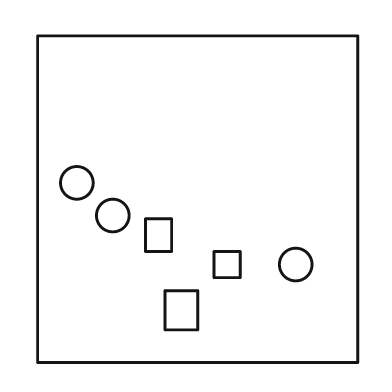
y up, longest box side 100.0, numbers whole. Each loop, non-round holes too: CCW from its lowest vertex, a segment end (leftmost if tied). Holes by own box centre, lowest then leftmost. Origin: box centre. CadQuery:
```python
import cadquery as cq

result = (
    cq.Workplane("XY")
    .moveTo(-49.0, -50.0)
    .lineTo(49.0, -50.0)
    .lineTo(49.0, 50.0)
    .lineTo(-49.0, 50.0)
    .close()
    .moveTo(-10.0, -40.0)
    .lineTo(0.0, -40.0)
    .lineTo(0.0, -28.0)
    .lineTo(-10.0, -28.0)
    .close()
    .moveTo(5.0, -24.0)
    .lineTo(13.0, -24.0)
    .lineTo(13.0, -16.0)
    .lineTo(5.0, -16.0)
    .close()
    .moveTo(30.0, -20.0)
    .circle(5.0)
    .moveTo(-16.0, -16.0)
    .lineTo(-8.0, -16.0)
    .lineTo(-8.0, -6.0)
    .lineTo(-16.0, -6.0)
    .close()
    .moveTo(-26.0, -5.0)
    .circle(5.0)
    .moveTo(-37.0, 5.0)
    .circle(5.0)
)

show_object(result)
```